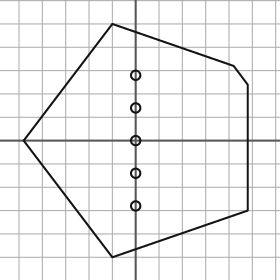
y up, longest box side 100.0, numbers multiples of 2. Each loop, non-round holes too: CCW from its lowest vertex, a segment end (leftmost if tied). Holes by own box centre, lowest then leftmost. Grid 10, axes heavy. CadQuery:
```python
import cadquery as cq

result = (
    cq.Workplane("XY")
    .moveTo(-10.0, -50.0)
    .lineTo(48.0, -30.0)
    .lineTo(48.0, 24.0)
    .lineTo(42.0, 32.0)
    .lineTo(-10.0, 50.0)
    .lineTo(-48.0, 0.0)
    .close()
    .moveTo(0.0, -28.0)
    .circle(2.0)
    .moveTo(0.0, -14.0)
    .circle(2.0)
    .moveTo(0.0, 0.0)
    .circle(2.0)
    .moveTo(0.0, 14.0)
    .circle(2.0)
    .moveTo(0.0, 28.0)
    .circle(2.0)
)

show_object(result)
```